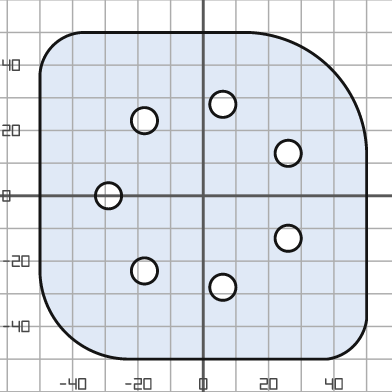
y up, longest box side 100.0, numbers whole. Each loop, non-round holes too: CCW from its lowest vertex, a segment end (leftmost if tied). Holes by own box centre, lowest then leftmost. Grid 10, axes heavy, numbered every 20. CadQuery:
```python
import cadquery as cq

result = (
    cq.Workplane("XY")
    .moveTo(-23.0, -50.0)
    .lineTo(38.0, -50.0)
    .threePointArc((46.0, -46.0), (50.0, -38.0))
    .lineTo(50.0, 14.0)
    .threePointArc((39.0, 39.0), (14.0, 50.0))
    .lineTo(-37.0, 50.0)
    .threePointArc((-46.0, 46.0), (-50.0, 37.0))
    .lineTo(-50.0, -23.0)
    .threePointArc((-42.0, -42.0), (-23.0, -50.0))
    .close()
    .moveTo(6.0, -28.0)
    .circle(4.0)
    .moveTo(-18.0, -23.0)
    .circle(4.0)
    .moveTo(26.0, -13.0)
    .circle(4.0)
    .moveTo(-29.0, 0.0)
    .circle(4.0)
    .moveTo(26.0, 13.0)
    .circle(4.0)
    .moveTo(-18.0, 23.0)
    .circle(4.0)
    .moveTo(6.0, 28.0)
    .circle(4.0)
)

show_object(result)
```